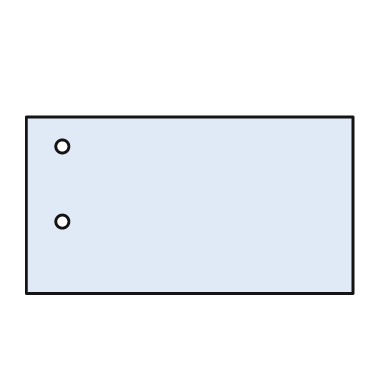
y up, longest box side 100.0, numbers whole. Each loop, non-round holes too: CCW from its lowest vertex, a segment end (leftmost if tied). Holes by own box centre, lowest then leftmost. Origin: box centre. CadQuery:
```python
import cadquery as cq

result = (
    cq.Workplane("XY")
    .moveTo(-50.0, -27.0)
    .lineTo(50.0, -27.0)
    .lineTo(50.0, 27.0)
    .lineTo(-50.0, 27.0)
    .close()
    .moveTo(-39.0, -5.0)
    .circle(2.0)
    .moveTo(-39.0, 18.0)
    .circle(2.0)
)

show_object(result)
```